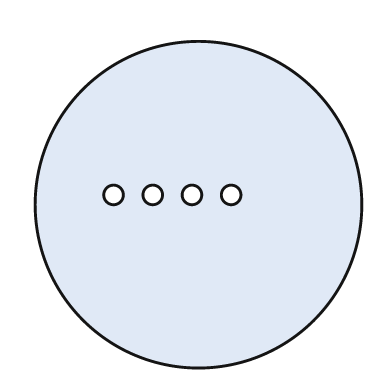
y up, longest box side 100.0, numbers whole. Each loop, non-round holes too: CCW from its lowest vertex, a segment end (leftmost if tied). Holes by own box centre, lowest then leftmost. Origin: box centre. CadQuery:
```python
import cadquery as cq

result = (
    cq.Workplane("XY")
    .moveTo(0.0, 0.0)
    .circle(50.0)
    .moveTo(-26.0, 3.0)
    .circle(3.0)
    .moveTo(-14.0, 3.0)
    .circle(3.0)
    .moveTo(-2.0, 3.0)
    .circle(3.0)
    .moveTo(10.0, 3.0)
    .circle(3.0)
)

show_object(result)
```